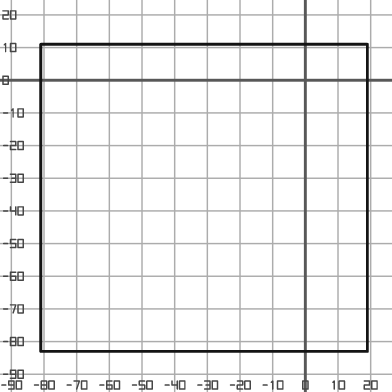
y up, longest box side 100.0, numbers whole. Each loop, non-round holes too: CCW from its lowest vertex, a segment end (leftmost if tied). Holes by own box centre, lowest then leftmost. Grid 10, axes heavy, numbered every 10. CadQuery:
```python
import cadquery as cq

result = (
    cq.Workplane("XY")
    .moveTo(-81.0, -83.0)
    .lineTo(19.0, -83.0)
    .lineTo(19.0, 11.0)
    .lineTo(-81.0, 11.0)
    .close()
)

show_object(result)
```